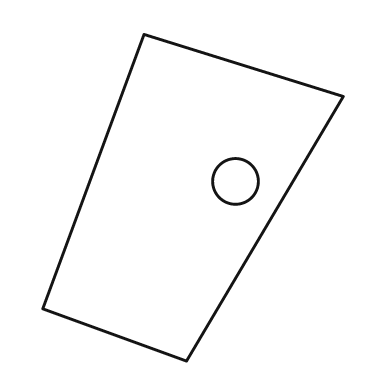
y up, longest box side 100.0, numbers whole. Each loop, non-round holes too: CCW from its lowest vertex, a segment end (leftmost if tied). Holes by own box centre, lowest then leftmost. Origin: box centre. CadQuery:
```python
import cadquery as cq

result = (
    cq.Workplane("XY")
    .moveTo(-2.0, -50.0)
    .lineTo(46.0, 31.0)
    .lineTo(-15.0, 50.0)
    .lineTo(-46.0, -34.0)
    .close()
    .moveTo(13.0, 5.0)
    .circle(7.0)
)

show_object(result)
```